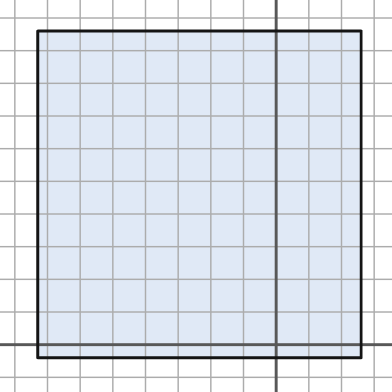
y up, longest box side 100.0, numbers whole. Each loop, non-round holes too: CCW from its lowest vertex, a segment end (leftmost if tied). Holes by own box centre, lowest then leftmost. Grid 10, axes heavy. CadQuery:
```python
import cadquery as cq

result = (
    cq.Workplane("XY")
    .moveTo(-73.0, -4.0)
    .lineTo(26.0, -4.0)
    .lineTo(26.0, 96.0)
    .lineTo(-73.0, 96.0)
    .close()
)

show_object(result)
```